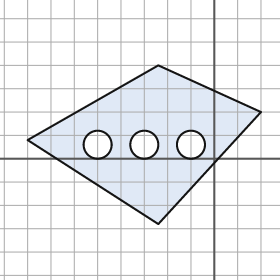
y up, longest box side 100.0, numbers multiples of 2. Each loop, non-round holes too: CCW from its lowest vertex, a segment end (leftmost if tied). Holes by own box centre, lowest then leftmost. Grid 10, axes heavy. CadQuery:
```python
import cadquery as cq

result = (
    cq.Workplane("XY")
    .moveTo(-24.0, -28.0)
    .lineTo(20.0, 20.0)
    .lineTo(-24.0, 40.0)
    .lineTo(-80.0, 8.0)
    .close()
    .moveTo(-50.0, 6.0)
    .circle(6.0)
    .moveTo(-30.0, 6.0)
    .circle(6.0)
    .moveTo(-10.0, 6.0)
    .circle(6.0)
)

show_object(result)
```